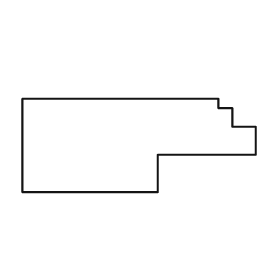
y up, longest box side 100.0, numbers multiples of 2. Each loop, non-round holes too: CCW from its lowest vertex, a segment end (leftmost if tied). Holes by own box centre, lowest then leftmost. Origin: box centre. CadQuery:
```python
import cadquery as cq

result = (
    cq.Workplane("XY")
    .moveTo(-50.0, -20.0)
    .lineTo(8.0, -20.0)
    .lineTo(8.0, -4.0)
    .lineTo(50.0, -4.0)
    .lineTo(50.0, 8.0)
    .lineTo(40.0, 8.0)
    .lineTo(40.0, 16.0)
    .lineTo(34.0, 16.0)
    .lineTo(34.0, 20.0)
    .lineTo(-50.0, 20.0)
    .close()
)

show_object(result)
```